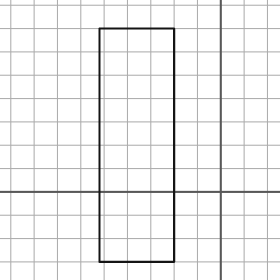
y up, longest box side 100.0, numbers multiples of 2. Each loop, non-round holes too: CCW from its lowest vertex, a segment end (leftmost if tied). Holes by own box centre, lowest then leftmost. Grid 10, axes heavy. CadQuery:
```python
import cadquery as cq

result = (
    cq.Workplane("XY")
    .moveTo(-52.0, -30.0)
    .lineTo(-20.0, -30.0)
    .lineTo(-20.0, 70.0)
    .lineTo(-52.0, 70.0)
    .close()
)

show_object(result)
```